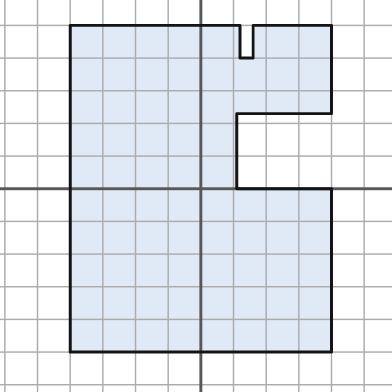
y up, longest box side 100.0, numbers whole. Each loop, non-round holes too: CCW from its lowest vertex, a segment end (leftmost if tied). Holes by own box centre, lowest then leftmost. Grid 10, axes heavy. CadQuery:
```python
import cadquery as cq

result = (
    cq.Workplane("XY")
    .moveTo(-40.0, -50.0)
    .lineTo(40.0, -50.0)
    .lineTo(40.0, 0.0)
    .lineTo(11.0, 0.0)
    .lineTo(11.0, 23.0)
    .lineTo(40.0, 23.0)
    .lineTo(40.0, 50.0)
    .lineTo(16.0, 50.0)
    .lineTo(16.0, 40.0)
    .lineTo(12.0, 40.0)
    .lineTo(12.0, 50.0)
    .lineTo(-40.0, 50.0)
    .close()
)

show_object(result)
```